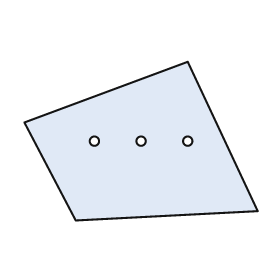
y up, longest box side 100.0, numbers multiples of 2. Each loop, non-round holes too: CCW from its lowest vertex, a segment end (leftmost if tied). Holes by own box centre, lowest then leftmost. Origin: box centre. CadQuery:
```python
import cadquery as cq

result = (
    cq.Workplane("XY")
    .moveTo(-28.0, -34.0)
    .lineTo(50.0, -30.0)
    .lineTo(20.0, 34.0)
    .lineTo(-50.0, 8.0)
    .close()
    .moveTo(-20.0, 0.0)
    .circle(2.0)
    .moveTo(0.0, 0.0)
    .circle(2.0)
    .moveTo(20.0, 0.0)
    .circle(2.0)
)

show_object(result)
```